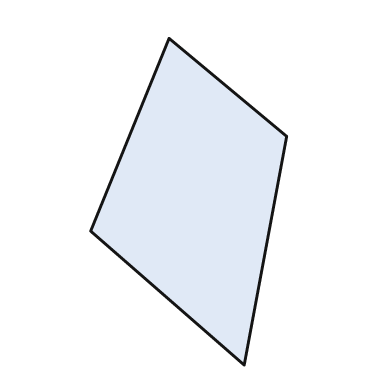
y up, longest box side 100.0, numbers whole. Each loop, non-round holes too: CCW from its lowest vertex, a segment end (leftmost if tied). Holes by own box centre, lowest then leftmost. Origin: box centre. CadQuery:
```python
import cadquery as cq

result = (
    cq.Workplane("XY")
    .moveTo(17.0, -50.0)
    .lineTo(30.0, 20.0)
    .lineTo(-6.0, 50.0)
    .lineTo(-30.0, -9.0)
    .close()
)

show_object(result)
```